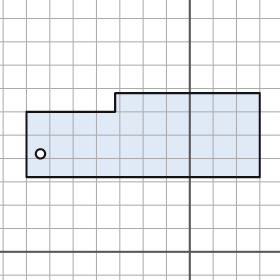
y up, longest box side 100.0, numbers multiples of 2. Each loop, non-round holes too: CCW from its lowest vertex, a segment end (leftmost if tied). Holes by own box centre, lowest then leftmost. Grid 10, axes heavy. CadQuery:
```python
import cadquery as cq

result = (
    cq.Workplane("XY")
    .moveTo(-70.0, 32.0)
    .lineTo(30.0, 32.0)
    .lineTo(30.0, 68.0)
    .lineTo(-32.0, 68.0)
    .lineTo(-32.0, 60.0)
    .lineTo(-70.0, 60.0)
    .close()
    .moveTo(-64.0, 42.0)
    .circle(2.0)
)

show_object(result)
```